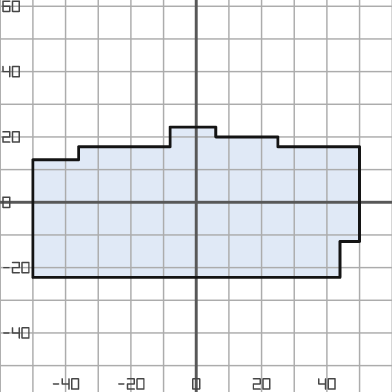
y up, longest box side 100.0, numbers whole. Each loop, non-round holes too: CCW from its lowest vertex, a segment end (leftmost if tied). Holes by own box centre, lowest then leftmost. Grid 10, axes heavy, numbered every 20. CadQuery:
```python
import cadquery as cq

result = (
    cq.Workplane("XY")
    .moveTo(-50.0, -23.0)
    .lineTo(44.0, -23.0)
    .lineTo(44.0, -12.0)
    .lineTo(50.0, -12.0)
    .lineTo(50.0, 17.0)
    .lineTo(25.0, 17.0)
    .lineTo(25.0, 20.0)
    .lineTo(6.0, 20.0)
    .lineTo(6.0, 23.0)
    .lineTo(-8.0, 23.0)
    .lineTo(-8.0, 17.0)
    .lineTo(-36.0, 17.0)
    .lineTo(-36.0, 13.0)
    .lineTo(-50.0, 13.0)
    .close()
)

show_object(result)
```